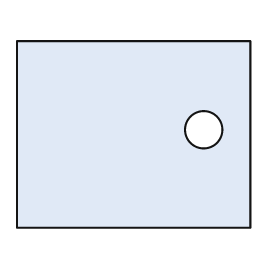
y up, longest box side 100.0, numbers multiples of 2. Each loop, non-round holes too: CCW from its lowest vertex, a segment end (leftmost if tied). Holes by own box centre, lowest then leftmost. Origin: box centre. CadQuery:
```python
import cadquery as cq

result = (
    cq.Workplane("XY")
    .moveTo(-50.0, -40.0)
    .lineTo(50.0, -40.0)
    .lineTo(50.0, 40.0)
    .lineTo(-50.0, 40.0)
    .close()
    .moveTo(30.0, 2.0)
    .circle(8.0)
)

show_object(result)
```